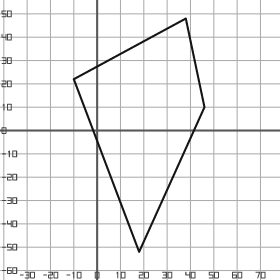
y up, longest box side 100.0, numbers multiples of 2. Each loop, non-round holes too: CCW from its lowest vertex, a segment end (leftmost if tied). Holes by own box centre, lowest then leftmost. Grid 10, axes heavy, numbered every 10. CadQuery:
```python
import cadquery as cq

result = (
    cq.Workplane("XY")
    .moveTo(18.0, -52.0)
    .lineTo(46.0, 10.0)
    .lineTo(38.0, 48.0)
    .lineTo(-10.0, 22.0)
    .close()
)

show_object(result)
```